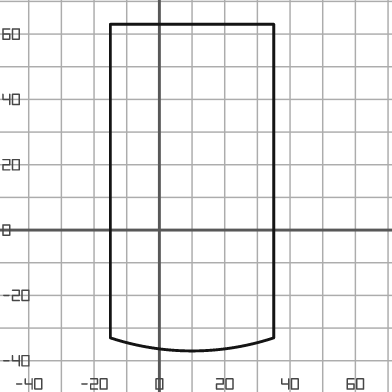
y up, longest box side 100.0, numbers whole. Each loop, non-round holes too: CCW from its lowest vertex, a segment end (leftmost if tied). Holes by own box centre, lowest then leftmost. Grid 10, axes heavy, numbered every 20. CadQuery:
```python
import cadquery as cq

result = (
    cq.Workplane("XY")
    .moveTo(-15.0, -33.0)
    .threePointArc((10.0, -37.0), (35.0, -33.0))
    .lineTo(35.0, 63.0)
    .lineTo(-15.0, 63.0)
    .close()
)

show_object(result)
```